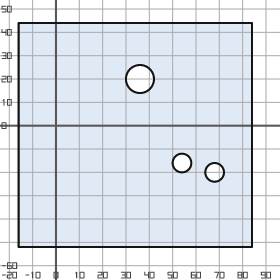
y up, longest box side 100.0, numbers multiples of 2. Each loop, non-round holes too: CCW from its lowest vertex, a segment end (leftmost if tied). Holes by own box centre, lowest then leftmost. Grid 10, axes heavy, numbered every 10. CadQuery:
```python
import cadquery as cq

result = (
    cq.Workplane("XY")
    .moveTo(-16.0, -52.0)
    .lineTo(84.0, -52.0)
    .lineTo(84.0, 44.0)
    .lineTo(-16.0, 44.0)
    .close()
    .moveTo(68.0, -20.0)
    .circle(4.0)
    .moveTo(54.0, -16.0)
    .circle(4.0)
    .moveTo(36.0, 20.0)
    .circle(6.0)
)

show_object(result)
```